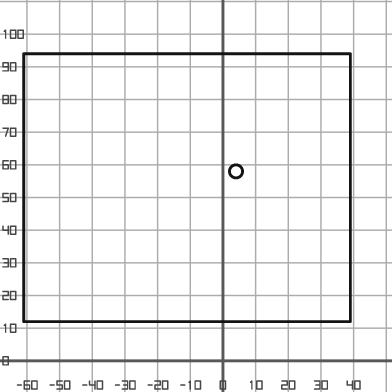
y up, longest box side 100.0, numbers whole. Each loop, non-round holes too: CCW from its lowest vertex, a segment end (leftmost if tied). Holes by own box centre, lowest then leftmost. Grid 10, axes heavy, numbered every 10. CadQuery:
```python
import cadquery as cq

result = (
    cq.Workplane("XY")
    .moveTo(-61.0, 12.0)
    .lineTo(39.0, 12.0)
    .lineTo(39.0, 94.0)
    .lineTo(-61.0, 94.0)
    .close()
    .moveTo(4.0, 58.0)
    .circle(2.0)
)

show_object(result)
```